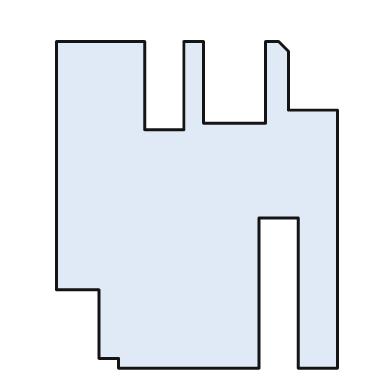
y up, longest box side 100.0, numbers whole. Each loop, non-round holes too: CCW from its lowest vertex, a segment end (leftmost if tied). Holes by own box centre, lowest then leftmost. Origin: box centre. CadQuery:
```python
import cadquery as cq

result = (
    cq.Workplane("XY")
    .moveTo(-24.0, -50.0)
    .lineTo(19.0, -50.0)
    .lineTo(19.0, -4.0)
    .lineTo(31.0, -4.0)
    .lineTo(31.0, -50.0)
    .lineTo(43.0, -50.0)
    .lineTo(43.0, 29.0)
    .lineTo(28.0, 29.0)
    .lineTo(28.0, 47.0)
    .lineTo(25.0, 50.0)
    .lineTo(21.0, 50.0)
    .lineTo(21.0, 25.0)
    .lineTo(2.0, 25.0)
    .lineTo(2.0, 50.0)
    .lineTo(-4.0, 50.0)
    .lineTo(-4.0, 23.0)
    .lineTo(-16.0, 23.0)
    .lineTo(-16.0, 50.0)
    .lineTo(-43.0, 50.0)
    .lineTo(-43.0, -26.0)
    .lineTo(-30.0, -26.0)
    .lineTo(-30.0, -47.0)
    .lineTo(-24.0, -47.0)
    .close()
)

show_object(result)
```